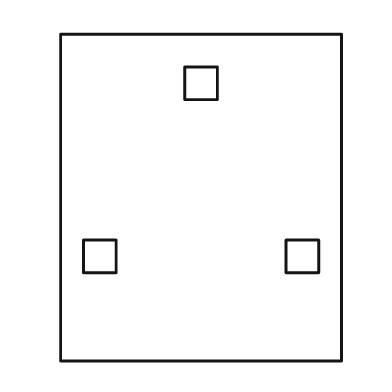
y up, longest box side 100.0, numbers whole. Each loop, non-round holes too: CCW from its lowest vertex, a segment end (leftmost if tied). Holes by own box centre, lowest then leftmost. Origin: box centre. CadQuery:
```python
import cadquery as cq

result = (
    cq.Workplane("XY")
    .moveTo(-43.0, -50.0)
    .lineTo(43.0, -50.0)
    .lineTo(43.0, 50.0)
    .lineTo(-43.0, 50.0)
    .close()
    .moveTo(-36.0, -23.0)
    .lineTo(-26.0, -23.0)
    .lineTo(-26.0, -13.0)
    .lineTo(-36.0, -13.0)
    .close()
    .moveTo(26.0, -23.0)
    .lineTo(36.0, -23.0)
    .lineTo(36.0, -13.0)
    .lineTo(26.0, -13.0)
    .close()
    .moveTo(-5.0, 30.0)
    .lineTo(5.0, 30.0)
    .lineTo(5.0, 40.0)
    .lineTo(-5.0, 40.0)
    .close()
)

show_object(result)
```